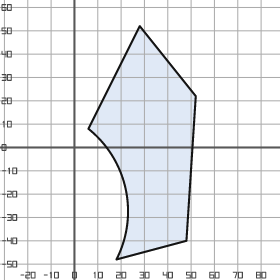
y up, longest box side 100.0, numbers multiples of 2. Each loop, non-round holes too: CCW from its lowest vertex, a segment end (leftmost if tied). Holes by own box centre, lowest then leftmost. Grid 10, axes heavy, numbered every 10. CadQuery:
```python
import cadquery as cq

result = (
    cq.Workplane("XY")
    .moveTo(18.0, -48.0)
    .lineTo(48.0, -40.0)
    .lineTo(52.0, 22.0)
    .lineTo(28.0, 52.0)
    .lineTo(6.0, 8.0)
    .threePointArc((22.0, -18.0), (18.0, -48.0))
    .close()
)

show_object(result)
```